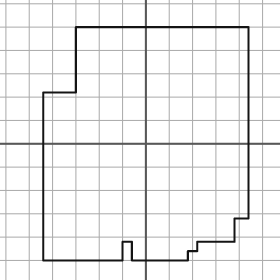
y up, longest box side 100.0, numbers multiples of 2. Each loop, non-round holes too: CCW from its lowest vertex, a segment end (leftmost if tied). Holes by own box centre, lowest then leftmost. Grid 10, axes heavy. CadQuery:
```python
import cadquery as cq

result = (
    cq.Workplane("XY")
    .moveTo(-44.0, -50.0)
    .lineTo(-10.0, -50.0)
    .lineTo(-10.0, -42.0)
    .lineTo(-6.0, -42.0)
    .lineTo(-6.0, -50.0)
    .lineTo(18.0, -50.0)
    .lineTo(18.0, -46.0)
    .lineTo(22.0, -46.0)
    .lineTo(22.0, -42.0)
    .lineTo(38.0, -42.0)
    .lineTo(38.0, -32.0)
    .lineTo(44.0, -32.0)
    .lineTo(44.0, 50.0)
    .lineTo(-30.0, 50.0)
    .lineTo(-30.0, 22.0)
    .lineTo(-44.0, 22.0)
    .close()
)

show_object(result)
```